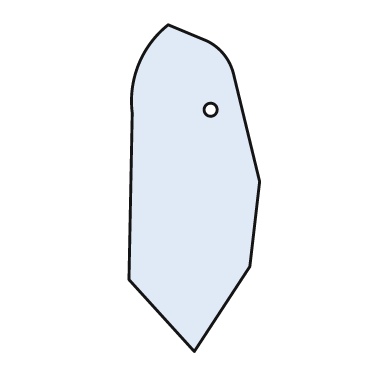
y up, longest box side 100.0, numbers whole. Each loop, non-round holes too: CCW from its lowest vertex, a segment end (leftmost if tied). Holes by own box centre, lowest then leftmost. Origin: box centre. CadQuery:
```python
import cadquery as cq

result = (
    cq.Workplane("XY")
    .moveTo(0.0, -50.0)
    .lineTo(17.0, -24.0)
    .lineTo(20.0, 2.0)
    .lineTo(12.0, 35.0)
    .threePointArc((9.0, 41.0), (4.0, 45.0))
    .lineTo(-8.0, 50.0)
    .threePointArc((-17.0, 38.0), (-19.0, 23.0))
    .lineTo(-20.0, -28.0)
    .close()
    .moveTo(5.0, 24.0)
    .circle(2.0)
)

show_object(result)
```